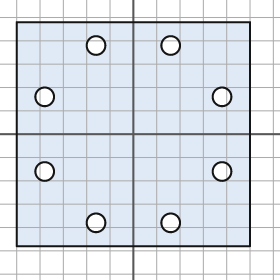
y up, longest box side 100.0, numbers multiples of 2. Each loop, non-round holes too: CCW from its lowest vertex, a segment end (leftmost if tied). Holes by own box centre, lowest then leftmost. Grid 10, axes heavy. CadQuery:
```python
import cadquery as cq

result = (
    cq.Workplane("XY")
    .moveTo(-50.0, -48.0)
    .lineTo(50.0, -48.0)
    .lineTo(50.0, 48.0)
    .lineTo(-50.0, 48.0)
    .close()
    .moveTo(-16.0, -38.0)
    .circle(4.0)
    .moveTo(16.0, -38.0)
    .circle(4.0)
    .moveTo(-38.0, -16.0)
    .circle(4.0)
    .moveTo(38.0, -16.0)
    .circle(4.0)
    .moveTo(-38.0, 16.0)
    .circle(4.0)
    .moveTo(38.0, 16.0)
    .circle(4.0)
    .moveTo(-16.0, 38.0)
    .circle(4.0)
    .moveTo(16.0, 38.0)
    .circle(4.0)
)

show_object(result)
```